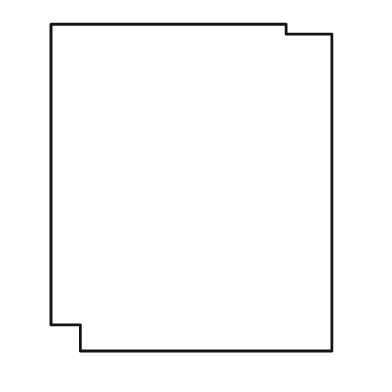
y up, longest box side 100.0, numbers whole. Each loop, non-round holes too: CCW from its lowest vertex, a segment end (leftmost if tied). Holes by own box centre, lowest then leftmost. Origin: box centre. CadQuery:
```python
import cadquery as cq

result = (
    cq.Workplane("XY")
    .moveTo(-34.0, -50.0)
    .lineTo(43.0, -50.0)
    .lineTo(43.0, 47.0)
    .lineTo(29.0, 47.0)
    .lineTo(29.0, 50.0)
    .lineTo(-43.0, 50.0)
    .lineTo(-43.0, -42.0)
    .lineTo(-34.0, -42.0)
    .close()
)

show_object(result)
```